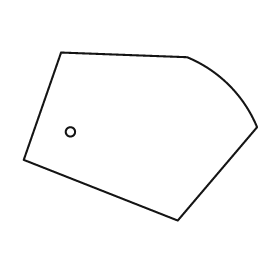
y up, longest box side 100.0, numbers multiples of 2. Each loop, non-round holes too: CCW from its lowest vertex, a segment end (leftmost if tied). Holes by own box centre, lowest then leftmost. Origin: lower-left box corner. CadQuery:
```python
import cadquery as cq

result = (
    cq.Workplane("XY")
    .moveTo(66.0, 0.0)
    .lineTo(100.0, 40.0)
    .threePointArc((88.0, 58.0), (70.0, 70.0))
    .lineTo(16.0, 72.0)
    .lineTo(0.0, 26.0)
    .close()
    .moveTo(20.0, 38.0)
    .circle(2.0)
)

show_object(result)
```